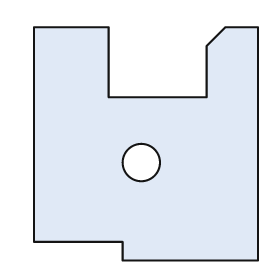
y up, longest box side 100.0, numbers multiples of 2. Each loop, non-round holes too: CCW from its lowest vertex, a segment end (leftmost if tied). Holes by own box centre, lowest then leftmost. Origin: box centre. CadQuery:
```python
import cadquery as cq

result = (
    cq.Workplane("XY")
    .moveTo(-10.0, -50.0)
    .lineTo(48.0, -50.0)
    .lineTo(48.0, 50.0)
    .lineTo(34.0, 50.0)
    .lineTo(26.0, 42.0)
    .lineTo(26.0, 20.0)
    .lineTo(-16.0, 20.0)
    .lineTo(-16.0, 50.0)
    .lineTo(-48.0, 50.0)
    .lineTo(-48.0, -42.0)
    .lineTo(-10.0, -42.0)
    .close()
    .moveTo(-2.0, -8.0)
    .circle(8.0)
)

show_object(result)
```